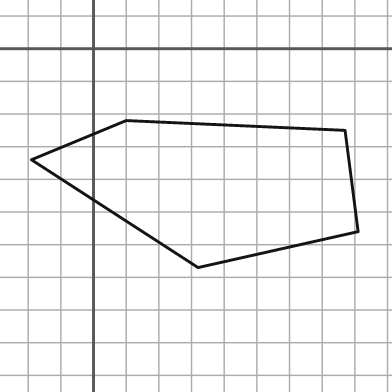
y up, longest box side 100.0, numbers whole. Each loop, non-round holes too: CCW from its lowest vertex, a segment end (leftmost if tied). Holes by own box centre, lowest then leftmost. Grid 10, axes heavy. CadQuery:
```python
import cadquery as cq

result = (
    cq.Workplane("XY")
    .moveTo(32.0, -67.0)
    .lineTo(81.0, -56.0)
    .lineTo(77.0, -25.0)
    .lineTo(10.0, -22.0)
    .lineTo(-19.0, -34.0)
    .close()
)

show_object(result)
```